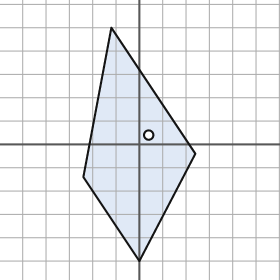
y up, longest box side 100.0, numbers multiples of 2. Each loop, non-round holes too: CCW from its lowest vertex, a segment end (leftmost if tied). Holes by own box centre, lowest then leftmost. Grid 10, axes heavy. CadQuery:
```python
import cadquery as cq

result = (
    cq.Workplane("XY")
    .moveTo(0.0, -50.0)
    .lineTo(24.0, -4.0)
    .lineTo(-12.0, 50.0)
    .lineTo(-24.0, -14.0)
    .close()
    .moveTo(4.0, 4.0)
    .circle(2.0)
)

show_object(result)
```